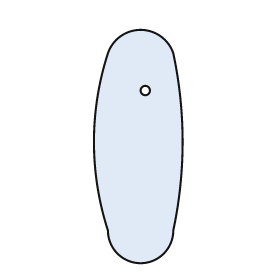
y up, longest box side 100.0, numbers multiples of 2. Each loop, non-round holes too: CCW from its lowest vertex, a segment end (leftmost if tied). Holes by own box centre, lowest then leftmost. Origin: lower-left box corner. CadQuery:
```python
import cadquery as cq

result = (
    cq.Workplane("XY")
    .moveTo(6.0, 14.0)
    .threePointArc((20.0, 0.0), (34.0, 14.0))
    .threePointArc((38.0, 52.0), (34.0, 90.0))
    .threePointArc((20.0, 100.0), (6.0, 90.0))
    .threePointArc((0.0, 52.0), (6.0, 14.0))
    .close()
    .moveTo(22.0, 74.0)
    .circle(2.0)
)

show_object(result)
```